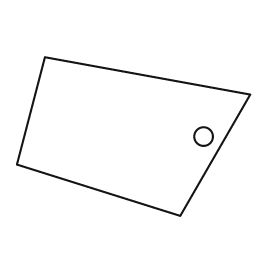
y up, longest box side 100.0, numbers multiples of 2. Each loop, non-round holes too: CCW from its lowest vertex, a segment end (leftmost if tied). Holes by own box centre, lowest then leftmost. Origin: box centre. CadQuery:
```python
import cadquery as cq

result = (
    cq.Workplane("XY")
    .moveTo(20.0, -34.0)
    .lineTo(50.0, 18.0)
    .lineTo(-38.0, 34.0)
    .lineTo(-50.0, -12.0)
    .close()
    .moveTo(30.0, 0.0)
    .circle(4.0)
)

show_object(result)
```